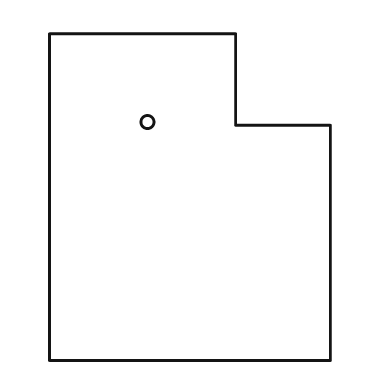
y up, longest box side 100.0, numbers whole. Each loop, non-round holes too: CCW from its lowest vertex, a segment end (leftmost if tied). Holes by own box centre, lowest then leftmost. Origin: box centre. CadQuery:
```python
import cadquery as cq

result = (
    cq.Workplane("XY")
    .moveTo(-43.0, -50.0)
    .lineTo(43.0, -50.0)
    .lineTo(43.0, 22.0)
    .lineTo(14.0, 22.0)
    .lineTo(14.0, 50.0)
    .lineTo(-43.0, 50.0)
    .close()
    .moveTo(-13.0, 23.0)
    .circle(2.0)
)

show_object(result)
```